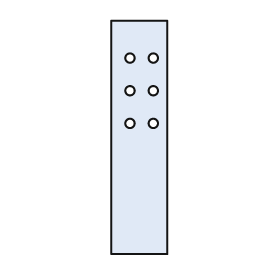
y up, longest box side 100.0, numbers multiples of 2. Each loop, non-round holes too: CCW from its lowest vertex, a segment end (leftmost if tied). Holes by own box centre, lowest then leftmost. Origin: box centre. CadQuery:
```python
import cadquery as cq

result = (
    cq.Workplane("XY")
    .moveTo(-12.0, -50.0)
    .lineTo(12.0, -50.0)
    .lineTo(12.0, 50.0)
    .lineTo(-12.0, 50.0)
    .close()
    .moveTo(-4.0, 6.0)
    .circle(2.0)
    .moveTo(6.0, 6.0)
    .circle(2.0)
    .moveTo(-4.0, 20.0)
    .circle(2.0)
    .moveTo(6.0, 20.0)
    .circle(2.0)
    .moveTo(-4.0, 34.0)
    .circle(2.0)
    .moveTo(6.0, 34.0)
    .circle(2.0)
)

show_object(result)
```